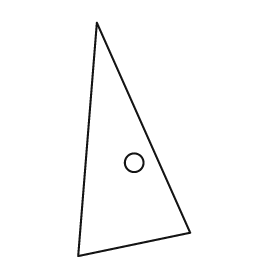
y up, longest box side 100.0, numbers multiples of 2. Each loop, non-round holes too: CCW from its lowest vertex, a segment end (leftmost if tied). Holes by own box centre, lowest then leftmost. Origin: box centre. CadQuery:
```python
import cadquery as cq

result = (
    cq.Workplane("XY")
    .moveTo(-24.0, -50.0)
    .lineTo(24.0, -40.0)
    .lineTo(-16.0, 50.0)
    .close()
    .moveTo(0.0, -10.0)
    .circle(4.0)
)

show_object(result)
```